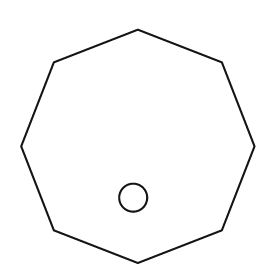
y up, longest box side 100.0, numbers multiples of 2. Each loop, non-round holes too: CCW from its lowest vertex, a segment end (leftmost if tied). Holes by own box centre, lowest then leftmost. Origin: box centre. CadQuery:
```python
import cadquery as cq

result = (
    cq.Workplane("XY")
    .moveTo(0.0, -50.0)
    .lineTo(36.0, -36.0)
    .lineTo(50.0, 0.0)
    .lineTo(36.0, 36.0)
    .lineTo(0.0, 50.0)
    .lineTo(-36.0, 36.0)
    .lineTo(-50.0, 0.0)
    .lineTo(-36.0, -36.0)
    .close()
    .moveTo(-2.0, -22.0)
    .circle(6.0)
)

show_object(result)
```